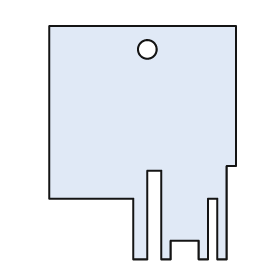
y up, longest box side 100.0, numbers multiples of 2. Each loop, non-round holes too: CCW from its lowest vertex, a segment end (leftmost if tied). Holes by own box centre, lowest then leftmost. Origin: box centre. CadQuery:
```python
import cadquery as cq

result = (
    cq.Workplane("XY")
    .moveTo(-4.0, -50.0)
    .lineTo(2.0, -50.0)
    .lineTo(2.0, -12.0)
    .lineTo(8.0, -12.0)
    .lineTo(8.0, -50.0)
    .lineTo(12.0, -50.0)
    .lineTo(12.0, -42.0)
    .lineTo(24.0, -42.0)
    .lineTo(24.0, -50.0)
    .lineTo(28.0, -50.0)
    .lineTo(28.0, -24.0)
    .lineTo(32.0, -24.0)
    .lineTo(32.0, -50.0)
    .lineTo(36.0, -50.0)
    .lineTo(36.0, -10.0)
    .lineTo(40.0, -10.0)
    .lineTo(40.0, 50.0)
    .lineTo(-40.0, 50.0)
    .lineTo(-40.0, -24.0)
    .lineTo(-4.0, -24.0)
    .close()
    .moveTo(2.0, 40.0)
    .circle(4.0)
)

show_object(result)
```